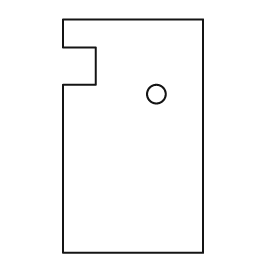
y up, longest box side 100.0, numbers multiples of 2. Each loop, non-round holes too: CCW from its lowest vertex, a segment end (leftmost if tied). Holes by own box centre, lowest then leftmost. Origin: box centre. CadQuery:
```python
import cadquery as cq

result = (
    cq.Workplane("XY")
    .moveTo(-30.0, -50.0)
    .lineTo(30.0, -50.0)
    .lineTo(30.0, 50.0)
    .lineTo(-30.0, 50.0)
    .lineTo(-30.0, 38.0)
    .lineTo(-16.0, 38.0)
    .lineTo(-16.0, 22.0)
    .lineTo(-30.0, 22.0)
    .close()
    .moveTo(10.0, 18.0)
    .circle(4.0)
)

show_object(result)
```